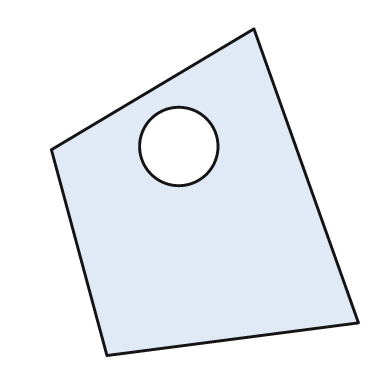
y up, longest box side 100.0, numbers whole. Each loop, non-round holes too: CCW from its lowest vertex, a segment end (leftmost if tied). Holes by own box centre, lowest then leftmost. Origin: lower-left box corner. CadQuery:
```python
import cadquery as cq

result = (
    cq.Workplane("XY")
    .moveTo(17.0, 0.0)
    .lineTo(94.0, 10.0)
    .lineTo(62.0, 100.0)
    .lineTo(0.0, 63.0)
    .close()
    .moveTo(39.0, 64.0)
    .circle(12.0)
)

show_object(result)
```